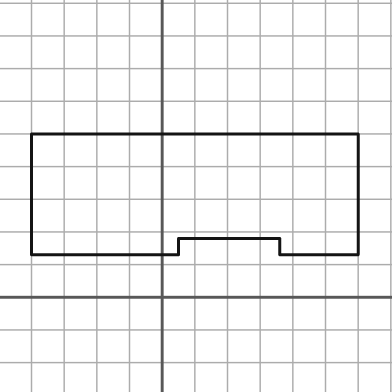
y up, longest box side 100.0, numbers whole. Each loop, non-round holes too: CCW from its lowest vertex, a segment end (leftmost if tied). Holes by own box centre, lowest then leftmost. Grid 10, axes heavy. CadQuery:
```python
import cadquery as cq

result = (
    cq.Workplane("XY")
    .moveTo(-40.0, 13.0)
    .lineTo(5.0, 13.0)
    .lineTo(5.0, 18.0)
    .lineTo(36.0, 18.0)
    .lineTo(36.0, 13.0)
    .lineTo(60.0, 13.0)
    .lineTo(60.0, 50.0)
    .lineTo(-40.0, 50.0)
    .close()
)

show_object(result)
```